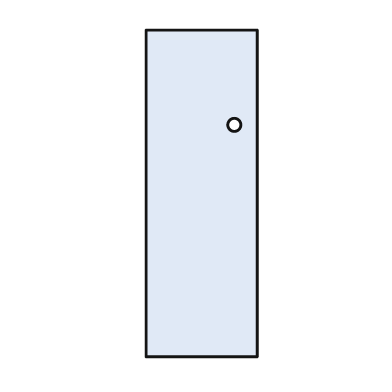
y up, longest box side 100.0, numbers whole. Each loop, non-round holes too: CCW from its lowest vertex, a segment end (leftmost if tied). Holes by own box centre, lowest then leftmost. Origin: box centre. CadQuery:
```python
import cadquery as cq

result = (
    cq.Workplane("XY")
    .moveTo(-17.0, -50.0)
    .lineTo(17.0, -50.0)
    .lineTo(17.0, 50.0)
    .lineTo(-17.0, 50.0)
    .close()
    .moveTo(10.0, 21.0)
    .circle(2.0)
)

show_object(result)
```